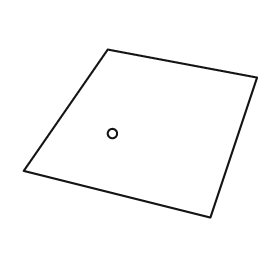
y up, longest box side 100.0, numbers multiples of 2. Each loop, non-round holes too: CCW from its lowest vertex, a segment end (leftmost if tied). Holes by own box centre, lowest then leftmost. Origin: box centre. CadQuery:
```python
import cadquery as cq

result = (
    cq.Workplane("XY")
    .moveTo(30.0, -36.0)
    .lineTo(50.0, 24.0)
    .lineTo(-14.0, 36.0)
    .lineTo(-50.0, -16.0)
    .close()
    .moveTo(-12.0, 0.0)
    .circle(2.0)
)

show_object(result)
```